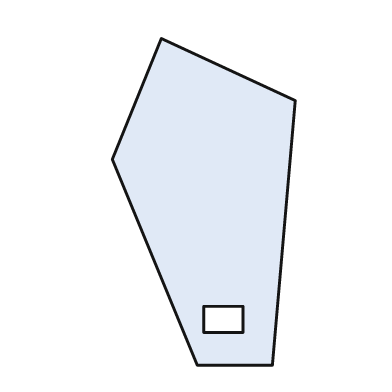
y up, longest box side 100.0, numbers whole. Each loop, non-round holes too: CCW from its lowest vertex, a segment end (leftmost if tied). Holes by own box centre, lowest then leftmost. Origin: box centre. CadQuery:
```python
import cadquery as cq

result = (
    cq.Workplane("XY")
    .moveTo(-2.0, -50.0)
    .lineTo(21.0, -50.0)
    .lineTo(28.0, 31.0)
    .lineTo(-13.0, 50.0)
    .lineTo(-28.0, 13.0)
    .close()
    .moveTo(0.0, -40.0)
    .lineTo(12.0, -40.0)
    .lineTo(12.0, -32.0)
    .lineTo(0.0, -32.0)
    .close()
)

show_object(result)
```